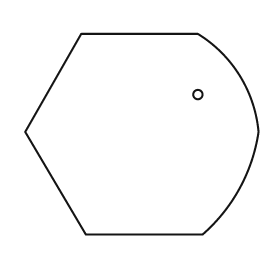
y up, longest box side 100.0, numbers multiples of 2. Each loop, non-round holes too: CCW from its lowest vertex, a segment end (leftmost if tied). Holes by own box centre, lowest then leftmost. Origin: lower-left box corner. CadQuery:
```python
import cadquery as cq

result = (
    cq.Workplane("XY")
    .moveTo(26.0, 0.0)
    .lineTo(76.0, 0.0)
    .threePointArc((92.0, 20.0), (100.0, 44.0))
    .threePointArc((92.0, 68.0), (74.0, 86.0))
    .lineTo(24.0, 86.0)
    .lineTo(0.0, 44.0)
    .close()
    .moveTo(74.0, 60.0)
    .circle(2.0)
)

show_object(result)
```